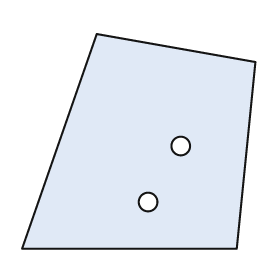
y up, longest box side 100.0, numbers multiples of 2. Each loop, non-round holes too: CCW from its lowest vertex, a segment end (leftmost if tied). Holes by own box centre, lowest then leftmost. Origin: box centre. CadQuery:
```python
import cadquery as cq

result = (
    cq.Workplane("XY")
    .moveTo(-50.0, -46.0)
    .lineTo(42.0, -46.0)
    .lineTo(50.0, 34.0)
    .lineTo(-18.0, 46.0)
    .close()
    .moveTo(4.0, -26.0)
    .circle(4.0)
    .moveTo(18.0, -2.0)
    .circle(4.0)
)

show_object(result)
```